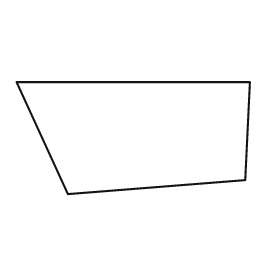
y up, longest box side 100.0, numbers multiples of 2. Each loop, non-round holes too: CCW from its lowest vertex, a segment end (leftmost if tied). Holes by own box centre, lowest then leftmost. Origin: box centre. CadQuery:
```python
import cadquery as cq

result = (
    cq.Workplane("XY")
    .moveTo(-28.0, -24.0)
    .lineTo(48.0, -18.0)
    .lineTo(50.0, 24.0)
    .lineTo(-50.0, 24.0)
    .close()
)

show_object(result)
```